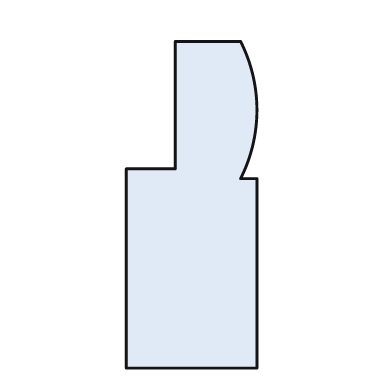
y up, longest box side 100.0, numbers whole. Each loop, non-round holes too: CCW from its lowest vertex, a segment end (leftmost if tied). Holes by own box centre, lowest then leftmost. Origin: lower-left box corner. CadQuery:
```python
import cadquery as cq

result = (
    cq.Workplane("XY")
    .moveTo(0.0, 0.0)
    .lineTo(40.0, 0.0)
    .lineTo(40.0, 58.0)
    .lineTo(35.0, 58.0)
    .threePointArc((40.0, 79.0), (35.0, 100.0))
    .lineTo(15.0, 100.0)
    .lineTo(15.0, 61.0)
    .lineTo(0.0, 61.0)
    .close()
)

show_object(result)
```